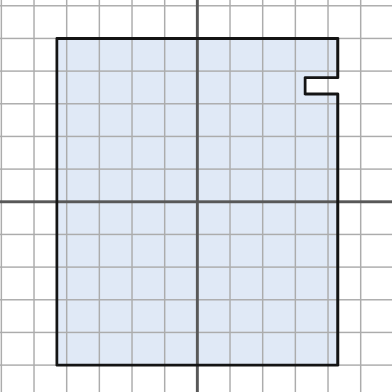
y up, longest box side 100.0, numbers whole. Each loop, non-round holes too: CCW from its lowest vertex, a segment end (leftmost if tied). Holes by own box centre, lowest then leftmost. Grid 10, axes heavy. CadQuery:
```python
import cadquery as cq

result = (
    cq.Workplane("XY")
    .moveTo(-43.0, -50.0)
    .lineTo(43.0, -50.0)
    .lineTo(43.0, 33.0)
    .lineTo(33.0, 33.0)
    .lineTo(33.0, 38.0)
    .lineTo(43.0, 38.0)
    .lineTo(43.0, 50.0)
    .lineTo(-43.0, 50.0)
    .close()
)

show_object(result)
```